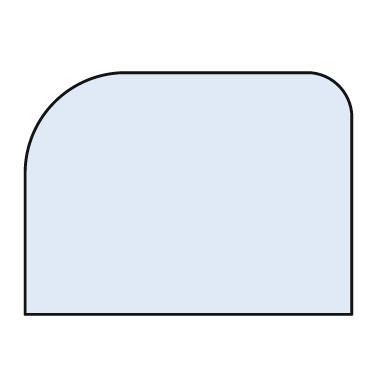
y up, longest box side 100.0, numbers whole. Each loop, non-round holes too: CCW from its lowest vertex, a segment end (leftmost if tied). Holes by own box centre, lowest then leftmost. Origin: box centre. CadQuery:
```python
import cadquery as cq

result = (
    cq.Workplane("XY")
    .moveTo(-50.0, -37.0)
    .lineTo(50.0, -37.0)
    .lineTo(50.0, 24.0)
    .threePointArc((46.0, 33.0), (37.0, 37.0))
    .lineTo(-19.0, 37.0)
    .threePointArc((-41.0, 28.0), (-50.0, 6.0))
    .close()
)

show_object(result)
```